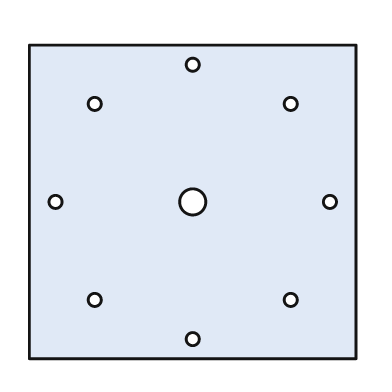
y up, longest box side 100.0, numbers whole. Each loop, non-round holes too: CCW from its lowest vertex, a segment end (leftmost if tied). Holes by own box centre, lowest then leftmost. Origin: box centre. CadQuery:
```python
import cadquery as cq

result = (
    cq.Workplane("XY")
    .moveTo(-50.0, -48.0)
    .lineTo(50.0, -48.0)
    .lineTo(50.0, 48.0)
    .lineTo(-50.0, 48.0)
    .close()
    .moveTo(0.0, -42.0)
    .circle(2.0)
    .moveTo(-30.0, -30.0)
    .circle(2.0)
    .moveTo(30.0, -30.0)
    .circle(2.0)
    .moveTo(-42.0, 0.0)
    .circle(2.0)
    .moveTo(0.0, 0.0)
    .circle(4.0)
    .moveTo(42.0, 0.0)
    .circle(2.0)
    .moveTo(-30.0, 30.0)
    .circle(2.0)
    .moveTo(30.0, 30.0)
    .circle(2.0)
    .moveTo(0.0, 42.0)
    .circle(2.0)
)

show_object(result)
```